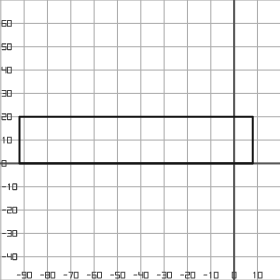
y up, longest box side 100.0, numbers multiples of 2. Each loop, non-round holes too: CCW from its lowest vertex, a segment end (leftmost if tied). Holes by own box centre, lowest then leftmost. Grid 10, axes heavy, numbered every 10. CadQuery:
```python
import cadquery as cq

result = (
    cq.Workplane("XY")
    .moveTo(-92.0, 0.0)
    .lineTo(8.0, 0.0)
    .lineTo(8.0, 20.0)
    .lineTo(-92.0, 20.0)
    .close()
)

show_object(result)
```